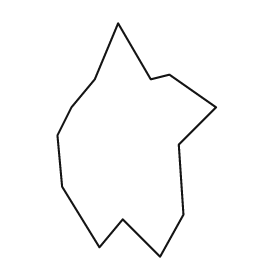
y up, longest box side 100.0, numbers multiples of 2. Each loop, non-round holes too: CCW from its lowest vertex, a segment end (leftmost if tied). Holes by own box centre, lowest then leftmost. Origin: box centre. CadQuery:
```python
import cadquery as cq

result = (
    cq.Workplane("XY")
    .moveTo(10.0, -50.0)
    .lineTo(20.0, -32.0)
    .lineTo(18.0, -2.0)
    .lineTo(34.0, 14.0)
    .lineTo(14.0, 28.0)
    .lineTo(6.0, 26.0)
    .lineTo(-8.0, 50.0)
    .lineTo(-18.0, 26.0)
    .lineTo(-28.0, 14.0)
    .lineTo(-34.0, 2.0)
    .lineTo(-32.0, -20.0)
    .lineTo(-16.0, -46.0)
    .lineTo(-6.0, -34.0)
    .close()
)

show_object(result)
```